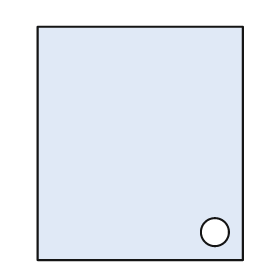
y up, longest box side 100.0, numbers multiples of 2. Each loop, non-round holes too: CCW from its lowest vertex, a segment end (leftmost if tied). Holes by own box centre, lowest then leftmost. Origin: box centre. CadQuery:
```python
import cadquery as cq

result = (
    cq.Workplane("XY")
    .moveTo(-44.0, -50.0)
    .lineTo(44.0, -50.0)
    .lineTo(44.0, 50.0)
    .lineTo(-44.0, 50.0)
    .close()
    .moveTo(32.0, -38.0)
    .circle(6.0)
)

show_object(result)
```